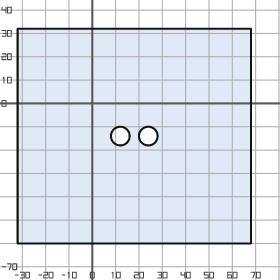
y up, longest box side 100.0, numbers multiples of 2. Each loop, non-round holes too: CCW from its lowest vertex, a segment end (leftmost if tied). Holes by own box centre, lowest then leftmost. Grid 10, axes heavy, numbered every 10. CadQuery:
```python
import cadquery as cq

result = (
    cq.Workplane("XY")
    .moveTo(-32.0, -60.0)
    .lineTo(68.0, -60.0)
    .lineTo(68.0, 32.0)
    .lineTo(-32.0, 32.0)
    .close()
    .moveTo(12.0, -14.0)
    .circle(4.0)
    .moveTo(24.0, -14.0)
    .circle(4.0)
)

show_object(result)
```